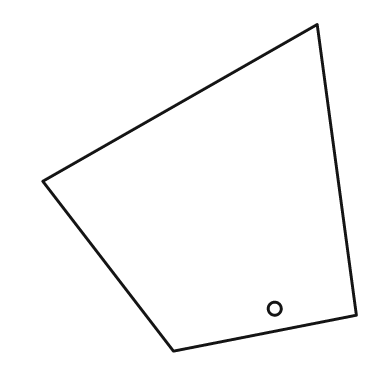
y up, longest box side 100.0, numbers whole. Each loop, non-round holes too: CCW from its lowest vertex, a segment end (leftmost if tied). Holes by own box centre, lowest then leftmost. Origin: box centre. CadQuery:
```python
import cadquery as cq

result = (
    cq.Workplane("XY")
    .moveTo(-8.0, -50.0)
    .lineTo(48.0, -39.0)
    .lineTo(36.0, 50.0)
    .lineTo(-48.0, 2.0)
    .close()
    .moveTo(23.0, -37.0)
    .circle(2.0)
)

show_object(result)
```